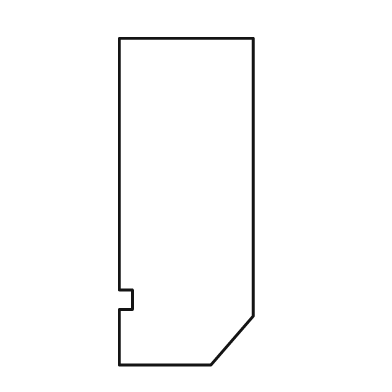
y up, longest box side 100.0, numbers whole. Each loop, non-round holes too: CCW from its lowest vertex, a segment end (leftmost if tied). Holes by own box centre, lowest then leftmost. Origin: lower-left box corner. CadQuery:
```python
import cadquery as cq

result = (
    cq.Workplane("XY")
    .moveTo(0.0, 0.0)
    .lineTo(28.0, 0.0)
    .lineTo(41.0, 15.0)
    .lineTo(41.0, 100.0)
    .lineTo(0.0, 100.0)
    .lineTo(0.0, 23.0)
    .lineTo(4.0, 23.0)
    .lineTo(4.0, 17.0)
    .lineTo(0.0, 17.0)
    .close()
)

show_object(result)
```